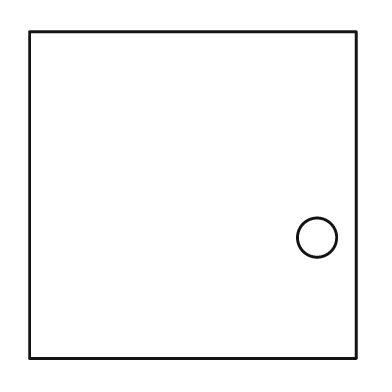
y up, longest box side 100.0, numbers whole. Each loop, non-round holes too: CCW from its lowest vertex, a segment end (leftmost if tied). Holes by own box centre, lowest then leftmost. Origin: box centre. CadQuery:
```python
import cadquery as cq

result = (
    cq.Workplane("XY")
    .moveTo(-50.0, -50.0)
    .lineTo(50.0, -50.0)
    .lineTo(50.0, 50.0)
    .lineTo(-50.0, 50.0)
    .close()
    .moveTo(38.0, -13.0)
    .circle(6.0)
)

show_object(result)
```